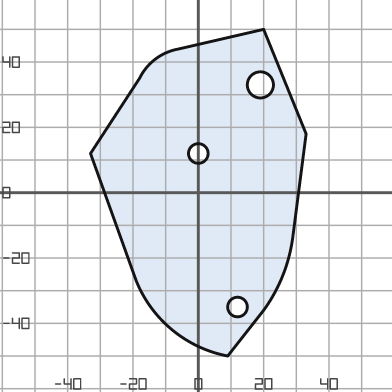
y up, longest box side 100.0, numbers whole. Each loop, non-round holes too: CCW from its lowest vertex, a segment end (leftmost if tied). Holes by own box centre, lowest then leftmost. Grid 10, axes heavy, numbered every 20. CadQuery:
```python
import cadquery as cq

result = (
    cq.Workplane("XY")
    .moveTo(9.0, -50.0)
    .lineTo(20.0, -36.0)
    .threePointArc((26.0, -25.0), (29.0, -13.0))
    .lineTo(33.0, 18.0)
    .lineTo(20.0, 50.0)
    .lineTo(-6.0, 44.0)
    .threePointArc((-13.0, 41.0), (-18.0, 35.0))
    .lineTo(-33.0, 12.0)
    .lineTo(-19.0, -27.0)
    .threePointArc((-8.0, -42.0), (9.0, -50.0))
    .close()
    .moveTo(12.0, -35.0)
    .circle(3.0)
    .moveTo(0.0, 12.0)
    .circle(3.0)
    .moveTo(19.0, 33.0)
    .circle(4.0)
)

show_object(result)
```